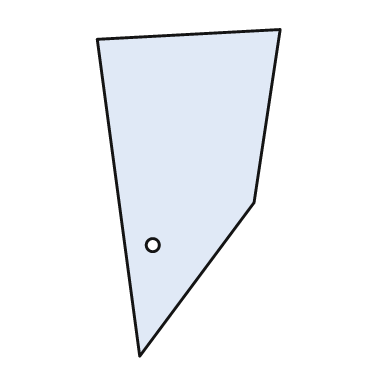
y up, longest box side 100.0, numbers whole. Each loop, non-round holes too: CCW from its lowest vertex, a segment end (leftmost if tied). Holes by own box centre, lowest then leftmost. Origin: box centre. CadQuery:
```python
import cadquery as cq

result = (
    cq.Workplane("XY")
    .moveTo(-15.0, -50.0)
    .lineTo(20.0, -3.0)
    .lineTo(28.0, 50.0)
    .lineTo(-28.0, 47.0)
    .close()
    .moveTo(-11.0, -16.0)
    .circle(2.0)
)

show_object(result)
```